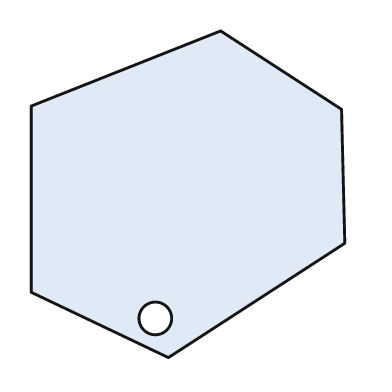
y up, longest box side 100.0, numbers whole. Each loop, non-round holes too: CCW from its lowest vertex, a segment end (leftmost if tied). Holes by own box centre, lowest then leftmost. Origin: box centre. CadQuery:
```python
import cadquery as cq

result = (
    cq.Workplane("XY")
    .moveTo(-6.0, -50.0)
    .lineTo(48.0, -15.0)
    .lineTo(47.0, 26.0)
    .lineTo(10.0, 50.0)
    .lineTo(-48.0, 27.0)
    .lineTo(-48.0, -30.0)
    .close()
    .moveTo(-10.0, -38.0)
    .circle(5.0)
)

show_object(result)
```